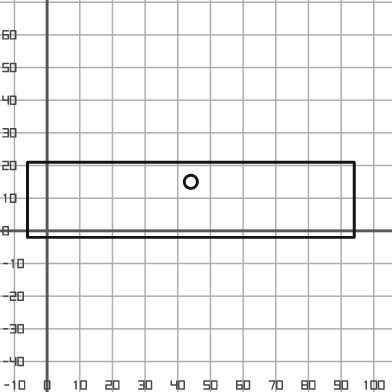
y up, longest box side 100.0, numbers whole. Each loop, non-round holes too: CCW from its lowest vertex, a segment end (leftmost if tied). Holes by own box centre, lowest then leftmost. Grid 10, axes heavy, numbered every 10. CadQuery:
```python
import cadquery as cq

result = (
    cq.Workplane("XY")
    .moveTo(-6.0, -2.0)
    .lineTo(94.0, -2.0)
    .lineTo(94.0, 21.0)
    .lineTo(-6.0, 21.0)
    .close()
    .moveTo(44.0, 15.0)
    .circle(2.0)
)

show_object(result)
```